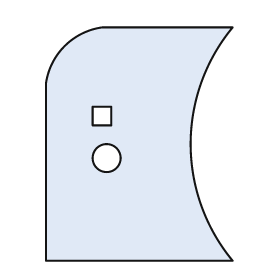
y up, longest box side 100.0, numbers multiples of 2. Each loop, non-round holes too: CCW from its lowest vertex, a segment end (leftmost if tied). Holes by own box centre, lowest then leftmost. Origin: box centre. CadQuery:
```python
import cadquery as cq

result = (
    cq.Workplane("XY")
    .moveTo(-40.0, -50.0)
    .lineTo(40.0, -50.0)
    .threePointArc((22.0, 0.0), (40.0, 50.0))
    .lineTo(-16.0, 50.0)
    .threePointArc((-32.0, 42.0), (-40.0, 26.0))
    .close()
    .moveTo(-14.0, -6.0)
    .circle(6.0)
    .moveTo(-20.0, 8.0)
    .lineTo(-12.0, 8.0)
    .lineTo(-12.0, 16.0)
    .lineTo(-20.0, 16.0)
    .close()
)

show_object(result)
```